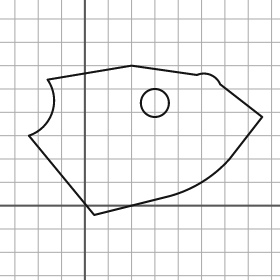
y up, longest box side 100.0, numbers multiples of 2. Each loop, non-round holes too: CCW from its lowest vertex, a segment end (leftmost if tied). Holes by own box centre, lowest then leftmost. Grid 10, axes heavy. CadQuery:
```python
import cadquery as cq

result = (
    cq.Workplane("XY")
    .moveTo(4.0, -4.0)
    .lineTo(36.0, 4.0)
    .threePointArc((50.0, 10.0), (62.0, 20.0))
    .lineTo(76.0, 38.0)
    .lineTo(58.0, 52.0)
    .threePointArc((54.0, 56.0), (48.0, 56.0))
    .lineTo(20.0, 60.0)
    .lineTo(-16.0, 54.0)
    .threePointArc((-14.0, 40.0), (-24.0, 30.0))
    .close()
    .moveTo(30.0, 44.0)
    .circle(6.0)
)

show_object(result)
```